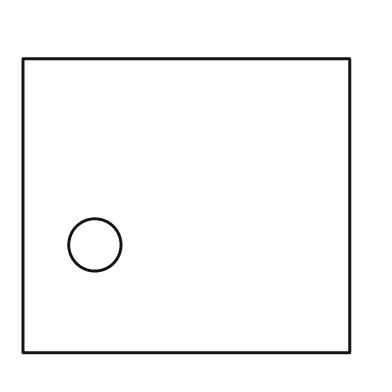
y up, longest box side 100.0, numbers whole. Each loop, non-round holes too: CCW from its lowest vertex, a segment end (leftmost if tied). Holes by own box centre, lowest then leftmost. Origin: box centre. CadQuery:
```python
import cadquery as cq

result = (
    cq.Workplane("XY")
    .moveTo(-50.0, -45.0)
    .lineTo(50.0, -45.0)
    .lineTo(50.0, 45.0)
    .lineTo(-50.0, 45.0)
    .close()
    .moveTo(-28.0, -12.0)
    .circle(8.0)
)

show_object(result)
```